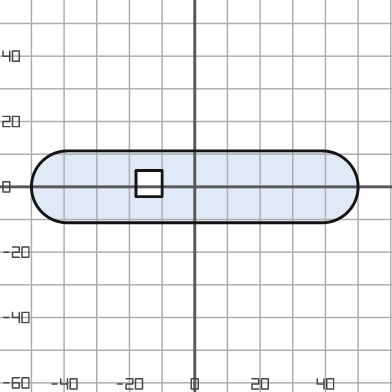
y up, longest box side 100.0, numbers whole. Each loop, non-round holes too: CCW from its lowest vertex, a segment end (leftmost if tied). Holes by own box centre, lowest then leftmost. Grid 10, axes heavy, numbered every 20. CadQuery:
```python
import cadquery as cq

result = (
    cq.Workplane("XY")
    .moveTo(-39.0, -11.0)
    .lineTo(39.0, -11.0)
    .threePointArc((50.0, 0.0), (39.0, 11.0))
    .lineTo(-39.0, 11.0)
    .threePointArc((-50.0, 0.0), (-39.0, -11.0))
    .close()
    .moveTo(-18.0, -3.0)
    .lineTo(-10.0, -3.0)
    .lineTo(-10.0, 5.0)
    .lineTo(-18.0, 5.0)
    .close()
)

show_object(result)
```